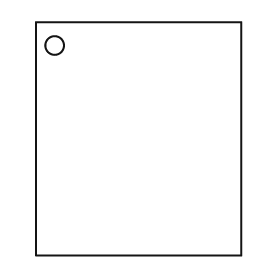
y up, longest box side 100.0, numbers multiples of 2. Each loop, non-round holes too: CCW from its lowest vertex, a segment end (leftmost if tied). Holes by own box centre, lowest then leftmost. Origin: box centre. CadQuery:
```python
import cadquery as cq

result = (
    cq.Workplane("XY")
    .moveTo(-44.0, -50.0)
    .lineTo(44.0, -50.0)
    .lineTo(44.0, 50.0)
    .lineTo(-44.0, 50.0)
    .close()
    .moveTo(-36.0, 40.0)
    .circle(4.0)
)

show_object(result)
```